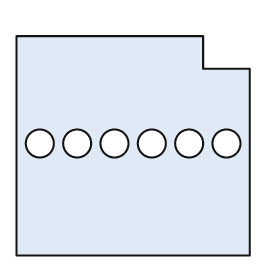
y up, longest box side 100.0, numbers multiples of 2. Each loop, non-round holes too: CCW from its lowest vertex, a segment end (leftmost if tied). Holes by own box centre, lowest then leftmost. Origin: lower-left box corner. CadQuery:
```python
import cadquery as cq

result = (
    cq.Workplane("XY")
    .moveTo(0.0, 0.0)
    .lineTo(100.0, 0.0)
    .lineTo(100.0, 80.0)
    .lineTo(80.0, 80.0)
    .lineTo(80.0, 94.0)
    .lineTo(0.0, 94.0)
    .close()
    .moveTo(10.0, 48.0)
    .circle(6.0)
    .moveTo(26.0, 48.0)
    .circle(6.0)
    .moveTo(42.0, 48.0)
    .circle(6.0)
    .moveTo(58.0, 48.0)
    .circle(6.0)
    .moveTo(74.0, 48.0)
    .circle(6.0)
    .moveTo(90.0, 48.0)
    .circle(6.0)
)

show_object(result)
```